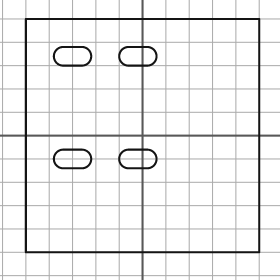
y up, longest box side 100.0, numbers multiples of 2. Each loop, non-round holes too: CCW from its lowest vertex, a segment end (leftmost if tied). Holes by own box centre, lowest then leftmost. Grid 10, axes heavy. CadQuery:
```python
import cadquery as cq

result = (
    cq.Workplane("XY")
    .moveTo(-50.0, -50.0)
    .lineTo(50.0, -50.0)
    .lineTo(50.0, 50.0)
    .lineTo(-50.0, 50.0)
    .close()
    .moveTo(-34.0, -14.0)
    .lineTo(-26.0, -14.0)
    .threePointArc((-22.0, -10.0), (-26.0, -6.0))
    .lineTo(-34.0, -6.0)
    .threePointArc((-38.0, -10.0), (-34.0, -14.0))
    .close()
    .moveTo(-6.0, -14.0)
    .lineTo(2.0, -14.0)
    .threePointArc((6.0, -10.0), (2.0, -6.0))
    .lineTo(-6.0, -6.0)
    .threePointArc((-10.0, -10.0), (-6.0, -14.0))
    .close()
    .moveTo(-34.0, 30.0)
    .lineTo(-26.0, 30.0)
    .threePointArc((-22.0, 34.0), (-26.0, 38.0))
    .lineTo(-34.0, 38.0)
    .threePointArc((-38.0, 34.0), (-34.0, 30.0))
    .close()
    .moveTo(-6.0, 30.0)
    .lineTo(2.0, 30.0)
    .threePointArc((6.0, 34.0), (2.0, 38.0))
    .lineTo(-6.0, 38.0)
    .threePointArc((-10.0, 34.0), (-6.0, 30.0))
    .close()
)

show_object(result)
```